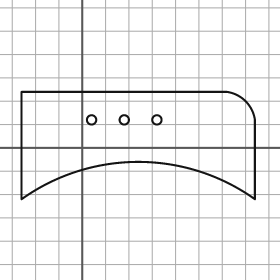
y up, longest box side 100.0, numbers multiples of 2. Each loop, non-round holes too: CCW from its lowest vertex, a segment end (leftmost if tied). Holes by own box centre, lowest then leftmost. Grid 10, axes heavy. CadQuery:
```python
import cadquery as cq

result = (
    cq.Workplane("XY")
    .moveTo(-26.0, -22.0)
    .threePointArc((24.0, -6.0), (74.0, -22.0))
    .lineTo(74.0, 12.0)
    .threePointArc((70.0, 20.0), (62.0, 24.0))
    .lineTo(-26.0, 24.0)
    .close()
    .moveTo(4.0, 12.0)
    .circle(2.0)
    .moveTo(18.0, 12.0)
    .circle(2.0)
    .moveTo(32.0, 12.0)
    .circle(2.0)
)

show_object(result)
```